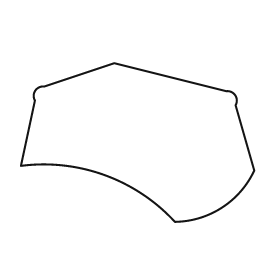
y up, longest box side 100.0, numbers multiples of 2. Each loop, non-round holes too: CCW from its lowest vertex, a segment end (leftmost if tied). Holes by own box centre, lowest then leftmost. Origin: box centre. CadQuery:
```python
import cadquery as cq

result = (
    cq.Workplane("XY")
    .moveTo(16.0, -34.0)
    .threePointArc((36.0, -28.0), (50.0, -12.0))
    .lineTo(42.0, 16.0)
    .threePointArc((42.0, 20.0), (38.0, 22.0))
    .lineTo(-10.0, 34.0)
    .lineTo(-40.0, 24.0)
    .threePointArc((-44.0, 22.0), (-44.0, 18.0))
    .lineTo(-50.0, -10.0)
    .threePointArc((-14.0, -14.0), (16.0, -34.0))
    .close()
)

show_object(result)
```